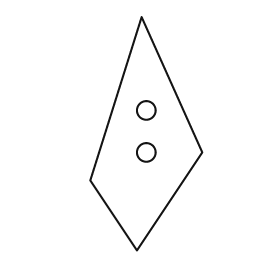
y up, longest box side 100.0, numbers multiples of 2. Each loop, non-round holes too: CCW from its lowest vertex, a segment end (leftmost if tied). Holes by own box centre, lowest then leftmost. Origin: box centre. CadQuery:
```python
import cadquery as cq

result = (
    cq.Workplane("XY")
    .moveTo(-4.0, -50.0)
    .lineTo(24.0, -8.0)
    .lineTo(-2.0, 50.0)
    .lineTo(-24.0, -20.0)
    .close()
    .moveTo(0.0, -8.0)
    .circle(4.0)
    .moveTo(0.0, 10.0)
    .circle(4.0)
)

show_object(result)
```